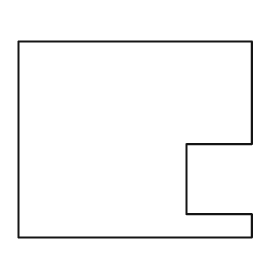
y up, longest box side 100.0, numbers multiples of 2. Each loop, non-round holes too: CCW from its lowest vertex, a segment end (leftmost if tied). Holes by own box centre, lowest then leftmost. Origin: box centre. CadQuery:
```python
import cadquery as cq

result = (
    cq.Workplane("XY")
    .moveTo(-50.0, -42.0)
    .lineTo(50.0, -42.0)
    .lineTo(50.0, -32.0)
    .lineTo(22.0, -32.0)
    .lineTo(22.0, -2.0)
    .lineTo(50.0, -2.0)
    .lineTo(50.0, 42.0)
    .lineTo(-50.0, 42.0)
    .close()
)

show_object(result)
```